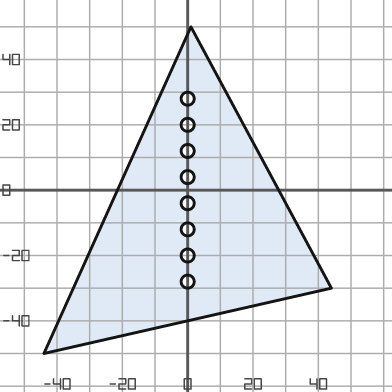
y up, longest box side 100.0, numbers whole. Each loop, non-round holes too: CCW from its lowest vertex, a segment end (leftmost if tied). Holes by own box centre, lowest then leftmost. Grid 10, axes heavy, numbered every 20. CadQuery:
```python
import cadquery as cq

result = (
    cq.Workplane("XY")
    .moveTo(-44.0, -50.0)
    .lineTo(44.0, -30.0)
    .lineTo(1.0, 50.0)
    .close()
    .moveTo(0.0, -28.0)
    .circle(2.0)
    .moveTo(0.0, -20.0)
    .circle(2.0)
    .moveTo(0.0, -12.0)
    .circle(2.0)
    .moveTo(0.0, -4.0)
    .circle(2.0)
    .moveTo(0.0, 4.0)
    .circle(2.0)
    .moveTo(0.0, 12.0)
    .circle(2.0)
    .moveTo(0.0, 20.0)
    .circle(2.0)
    .moveTo(0.0, 28.0)
    .circle(2.0)
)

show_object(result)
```